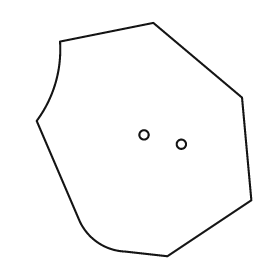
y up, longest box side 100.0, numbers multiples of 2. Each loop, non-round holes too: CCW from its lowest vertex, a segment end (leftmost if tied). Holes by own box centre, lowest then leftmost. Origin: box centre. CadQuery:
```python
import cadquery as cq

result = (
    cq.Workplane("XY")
    .moveTo(10.0, -50.0)
    .lineTo(46.0, -26.0)
    .lineTo(42.0, 18.0)
    .lineTo(4.0, 50.0)
    .lineTo(-36.0, 42.0)
    .threePointArc((-38.0, 24.0), (-46.0, 8.0))
    .lineTo(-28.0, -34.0)
    .threePointArc((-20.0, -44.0), (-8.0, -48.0))
    .close()
    .moveTo(16.0, -2.0)
    .circle(2.0)
    .moveTo(0.0, 2.0)
    .circle(2.0)
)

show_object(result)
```